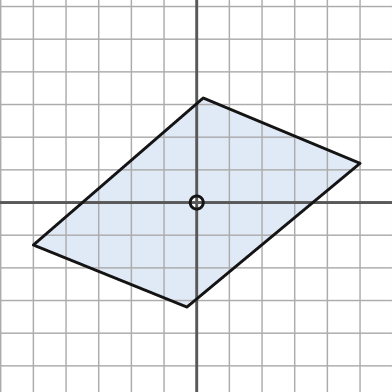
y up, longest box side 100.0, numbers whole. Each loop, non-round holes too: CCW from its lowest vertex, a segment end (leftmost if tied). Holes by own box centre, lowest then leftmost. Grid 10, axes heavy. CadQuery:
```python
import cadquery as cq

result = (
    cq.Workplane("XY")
    .moveTo(-3.0, -32.0)
    .lineTo(50.0, 12.0)
    .lineTo(2.0, 32.0)
    .lineTo(-50.0, -13.0)
    .close()
    .moveTo(0.0, 0.0)
    .circle(2.0)
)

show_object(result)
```